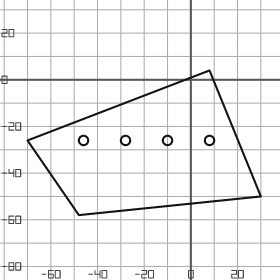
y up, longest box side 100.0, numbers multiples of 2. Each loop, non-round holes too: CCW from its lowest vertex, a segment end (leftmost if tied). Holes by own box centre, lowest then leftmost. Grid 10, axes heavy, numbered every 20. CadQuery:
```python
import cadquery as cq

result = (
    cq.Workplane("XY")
    .moveTo(-48.0, -58.0)
    .lineTo(30.0, -50.0)
    .lineTo(8.0, 4.0)
    .lineTo(-70.0, -26.0)
    .close()
    .moveTo(-46.0, -26.0)
    .circle(2.0)
    .moveTo(-28.0, -26.0)
    .circle(2.0)
    .moveTo(-10.0, -26.0)
    .circle(2.0)
    .moveTo(8.0, -26.0)
    .circle(2.0)
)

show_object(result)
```